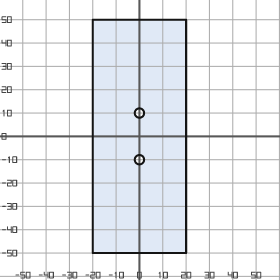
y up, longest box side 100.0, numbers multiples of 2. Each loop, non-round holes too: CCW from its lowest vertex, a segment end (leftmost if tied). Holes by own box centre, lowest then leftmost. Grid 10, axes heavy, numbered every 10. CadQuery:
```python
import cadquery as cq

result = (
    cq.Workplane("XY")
    .moveTo(-20.0, -50.0)
    .lineTo(20.0, -50.0)
    .lineTo(20.0, 50.0)
    .lineTo(-20.0, 50.0)
    .close()
    .moveTo(0.0, -10.0)
    .circle(2.0)
    .moveTo(0.0, 10.0)
    .circle(2.0)
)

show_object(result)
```